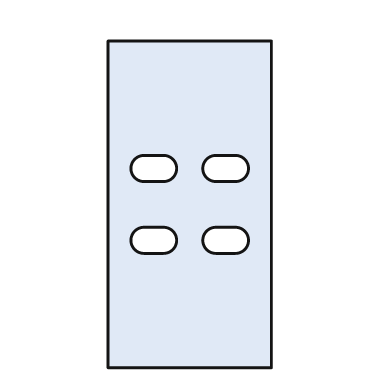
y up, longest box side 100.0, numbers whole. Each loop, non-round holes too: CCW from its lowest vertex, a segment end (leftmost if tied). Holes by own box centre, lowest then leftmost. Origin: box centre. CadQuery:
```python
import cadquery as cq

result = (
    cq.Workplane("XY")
    .moveTo(-25.0, -50.0)
    .lineTo(25.0, -50.0)
    .lineTo(25.0, 50.0)
    .lineTo(-25.0, 50.0)
    .close()
    .moveTo(-14.0, -15.0)
    .lineTo(-8.0, -15.0)
    .threePointArc((-4.0, -11.0), (-8.0, -7.0))
    .lineTo(-14.0, -7.0)
    .threePointArc((-18.0, -11.0), (-14.0, -15.0))
    .close()
    .moveTo(8.0, -15.0)
    .lineTo(14.0, -15.0)
    .threePointArc((18.0, -11.0), (14.0, -7.0))
    .lineTo(8.0, -7.0)
    .threePointArc((4.0, -11.0), (8.0, -15.0))
    .close()
    .moveTo(-14.0, 7.0)
    .lineTo(-8.0, 7.0)
    .threePointArc((-4.0, 11.0), (-8.0, 15.0))
    .lineTo(-14.0, 15.0)
    .threePointArc((-18.0, 11.0), (-14.0, 7.0))
    .close()
    .moveTo(8.0, 7.0)
    .lineTo(14.0, 7.0)
    .threePointArc((18.0, 11.0), (14.0, 15.0))
    .lineTo(8.0, 15.0)
    .threePointArc((4.0, 11.0), (8.0, 7.0))
    .close()
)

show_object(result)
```